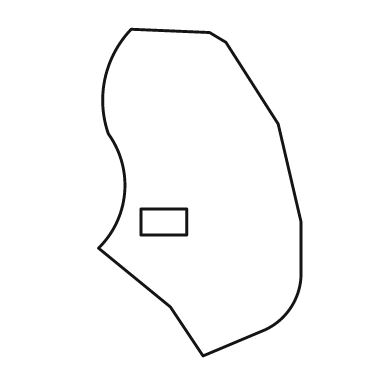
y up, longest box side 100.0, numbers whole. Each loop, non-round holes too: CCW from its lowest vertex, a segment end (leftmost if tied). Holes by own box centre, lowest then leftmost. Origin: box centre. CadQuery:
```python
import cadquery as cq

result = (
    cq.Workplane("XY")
    .moveTo(1.0, -50.0)
    .lineTo(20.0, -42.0)
    .threePointArc((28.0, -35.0), (31.0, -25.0))
    .lineTo(31.0, -9.0)
    .lineTo(24.0, 21.0)
    .lineTo(8.0, 46.0)
    .lineTo(3.0, 49.0)
    .lineTo(-21.0, 50.0)
    .threePointArc((-29.0, 35.0), (-28.0, 18.0))
    .threePointArc((-23.0, 0.0), (-31.0, -17.0))
    .lineTo(-9.0, -35.0)
    .close()
    .moveTo(-18.0, -13.0)
    .lineTo(-4.0, -13.0)
    .lineTo(-4.0, -5.0)
    .lineTo(-18.0, -5.0)
    .close()
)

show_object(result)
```